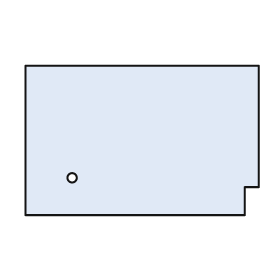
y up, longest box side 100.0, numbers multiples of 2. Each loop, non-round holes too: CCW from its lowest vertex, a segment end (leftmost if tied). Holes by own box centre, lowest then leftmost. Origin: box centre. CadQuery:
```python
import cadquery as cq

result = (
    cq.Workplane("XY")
    .moveTo(-50.0, -32.0)
    .lineTo(44.0, -32.0)
    .lineTo(44.0, -20.0)
    .lineTo(50.0, -20.0)
    .lineTo(50.0, 32.0)
    .lineTo(-50.0, 32.0)
    .close()
    .moveTo(-30.0, -16.0)
    .circle(2.0)
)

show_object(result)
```